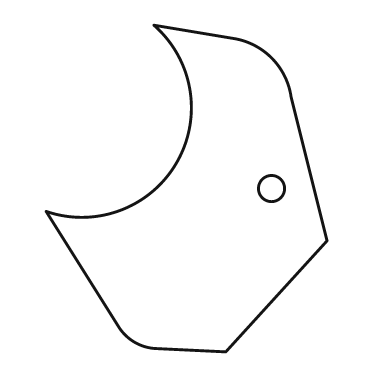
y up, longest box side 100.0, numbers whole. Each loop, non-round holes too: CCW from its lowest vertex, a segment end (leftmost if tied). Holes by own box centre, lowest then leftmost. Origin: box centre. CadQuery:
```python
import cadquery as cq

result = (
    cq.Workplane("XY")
    .moveTo(12.0, -50.0)
    .lineTo(43.0, -16.0)
    .lineTo(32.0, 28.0)
    .threePointArc((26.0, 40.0), (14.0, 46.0))
    .lineTo(-10.0, 50.0)
    .threePointArc((-3.0, 8.0), (-43.0, -7.0))
    .lineTo(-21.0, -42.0)
    .threePointArc((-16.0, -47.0), (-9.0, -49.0))
    .close()
    .moveTo(26.0, 0.0)
    .circle(4.0)
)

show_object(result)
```